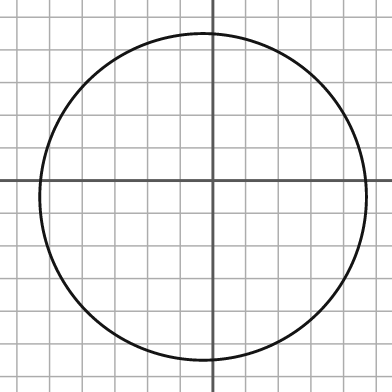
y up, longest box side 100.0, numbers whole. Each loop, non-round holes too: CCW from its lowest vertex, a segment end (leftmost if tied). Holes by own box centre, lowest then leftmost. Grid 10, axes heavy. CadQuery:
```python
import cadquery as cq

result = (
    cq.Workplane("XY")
    .moveTo(-3.0, -5.0)
    .circle(50.0)
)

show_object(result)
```